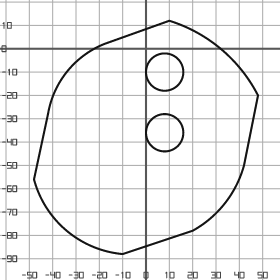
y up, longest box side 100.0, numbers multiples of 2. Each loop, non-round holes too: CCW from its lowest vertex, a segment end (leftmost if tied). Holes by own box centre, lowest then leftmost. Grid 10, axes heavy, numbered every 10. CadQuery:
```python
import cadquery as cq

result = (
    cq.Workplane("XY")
    .moveTo(-10.0, -88.0)
    .lineTo(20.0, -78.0)
    .threePointArc((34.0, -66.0), (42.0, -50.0))
    .lineTo(48.0, -20.0)
    .threePointArc((32.0, 0.0), (10.0, 12.0))
    .lineTo(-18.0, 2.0)
    .threePointArc((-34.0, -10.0), (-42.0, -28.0))
    .lineTo(-48.0, -56.0)
    .threePointArc((-34.0, -78.0), (-10.0, -88.0))
    .close()
    .moveTo(8.0, -36.0)
    .circle(8.0)
    .moveTo(8.0, -10.0)
    .circle(8.0)
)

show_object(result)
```